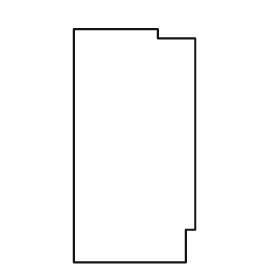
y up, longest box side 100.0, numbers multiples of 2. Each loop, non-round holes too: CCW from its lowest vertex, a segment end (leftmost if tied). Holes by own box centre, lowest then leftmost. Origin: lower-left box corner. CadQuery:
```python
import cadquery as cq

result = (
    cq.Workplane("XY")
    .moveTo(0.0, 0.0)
    .lineTo(48.0, 0.0)
    .lineTo(48.0, 14.0)
    .lineTo(52.0, 14.0)
    .lineTo(52.0, 96.0)
    .lineTo(36.0, 96.0)
    .lineTo(36.0, 100.0)
    .lineTo(0.0, 100.0)
    .close()
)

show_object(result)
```